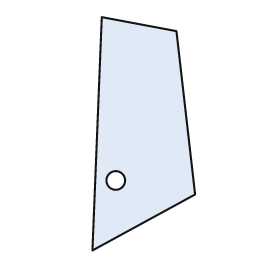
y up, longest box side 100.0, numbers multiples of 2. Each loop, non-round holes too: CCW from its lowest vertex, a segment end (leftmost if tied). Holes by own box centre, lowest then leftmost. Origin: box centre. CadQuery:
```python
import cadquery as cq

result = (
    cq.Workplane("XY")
    .moveTo(-22.0, -50.0)
    .lineTo(22.0, -26.0)
    .lineTo(14.0, 44.0)
    .lineTo(-18.0, 50.0)
    .close()
    .moveTo(-12.0, -20.0)
    .circle(4.0)
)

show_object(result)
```